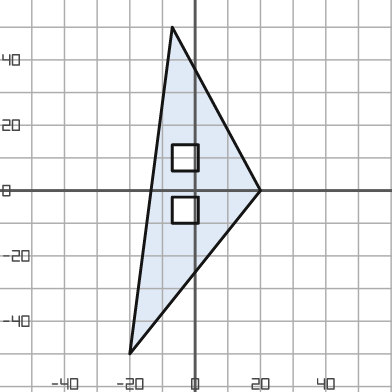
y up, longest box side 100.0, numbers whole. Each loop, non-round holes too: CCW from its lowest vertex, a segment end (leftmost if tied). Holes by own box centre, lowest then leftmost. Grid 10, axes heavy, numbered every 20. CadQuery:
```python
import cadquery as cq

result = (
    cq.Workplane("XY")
    .moveTo(-20.0, -50.0)
    .lineTo(20.0, 0.0)
    .lineTo(-7.0, 50.0)
    .close()
    .moveTo(-7.0, -10.0)
    .lineTo(1.0, -10.0)
    .lineTo(1.0, -2.0)
    .lineTo(-7.0, -2.0)
    .close()
    .moveTo(-7.0, 6.0)
    .lineTo(1.0, 6.0)
    .lineTo(1.0, 14.0)
    .lineTo(-7.0, 14.0)
    .close()
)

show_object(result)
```